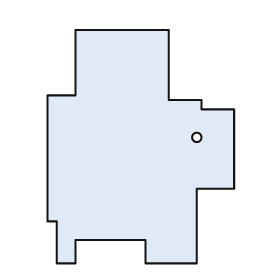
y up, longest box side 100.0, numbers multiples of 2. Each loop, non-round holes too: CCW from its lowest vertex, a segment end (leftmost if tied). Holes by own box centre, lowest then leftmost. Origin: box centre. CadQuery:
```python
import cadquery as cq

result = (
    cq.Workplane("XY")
    .moveTo(-36.0, -50.0)
    .lineTo(-28.0, -50.0)
    .lineTo(-28.0, -40.0)
    .lineTo(2.0, -40.0)
    .lineTo(2.0, -50.0)
    .lineTo(24.0, -50.0)
    .lineTo(24.0, -18.0)
    .lineTo(40.0, -18.0)
    .lineTo(40.0, 16.0)
    .lineTo(26.0, 16.0)
    .lineTo(26.0, 20.0)
    .lineTo(12.0, 20.0)
    .lineTo(12.0, 50.0)
    .lineTo(-28.0, 50.0)
    .lineTo(-28.0, 22.0)
    .lineTo(-40.0, 22.0)
    .lineTo(-40.0, -32.0)
    .lineTo(-36.0, -32.0)
    .close()
    .moveTo(24.0, 4.0)
    .circle(2.0)
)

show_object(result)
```